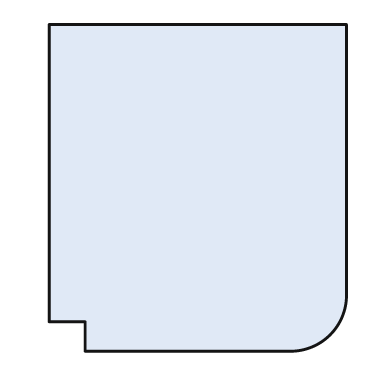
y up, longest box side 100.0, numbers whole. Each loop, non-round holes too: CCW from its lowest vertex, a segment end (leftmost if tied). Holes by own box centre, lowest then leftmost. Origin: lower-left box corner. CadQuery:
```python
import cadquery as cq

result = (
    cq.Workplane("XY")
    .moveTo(11.0, 0.0)
    .lineTo(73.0, 0.0)
    .threePointArc((86.0, 5.0), (91.0, 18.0))
    .lineTo(91.0, 100.0)
    .lineTo(0.0, 100.0)
    .lineTo(0.0, 9.0)
    .lineTo(11.0, 9.0)
    .close()
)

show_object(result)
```